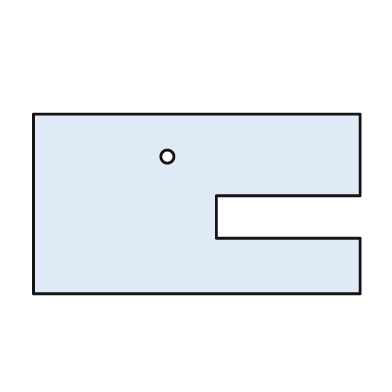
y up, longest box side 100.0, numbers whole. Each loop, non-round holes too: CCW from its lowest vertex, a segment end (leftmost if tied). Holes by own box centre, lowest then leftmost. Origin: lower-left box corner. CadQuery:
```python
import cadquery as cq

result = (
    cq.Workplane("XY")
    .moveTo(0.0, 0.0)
    .lineTo(100.0, 0.0)
    .lineTo(100.0, 17.0)
    .lineTo(56.0, 17.0)
    .lineTo(56.0, 30.0)
    .lineTo(100.0, 30.0)
    .lineTo(100.0, 55.0)
    .lineTo(0.0, 55.0)
    .close()
    .moveTo(41.0, 42.0)
    .circle(2.0)
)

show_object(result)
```